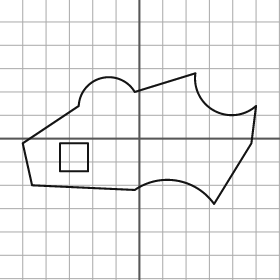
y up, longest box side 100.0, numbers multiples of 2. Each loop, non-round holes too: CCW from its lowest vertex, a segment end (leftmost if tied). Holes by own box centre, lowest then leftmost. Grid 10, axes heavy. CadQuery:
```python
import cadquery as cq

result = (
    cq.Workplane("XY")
    .moveTo(32.0, -28.0)
    .lineTo(48.0, -2.0)
    .lineTo(50.0, 14.0)
    .threePointArc((32.0, 12.0), (24.0, 28.0))
    .lineTo(-2.0, 20.0)
    .threePointArc((-16.0, 26.0), (-26.0, 14.0))
    .lineTo(-50.0, -2.0)
    .lineTo(-46.0, -20.0)
    .lineTo(-2.0, -22.0)
    .threePointArc((16.0, -18.0), (32.0, -28.0))
    .close()
    .moveTo(-34.0, -14.0)
    .lineTo(-22.0, -14.0)
    .lineTo(-22.0, -2.0)
    .lineTo(-34.0, -2.0)
    .close()
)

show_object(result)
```